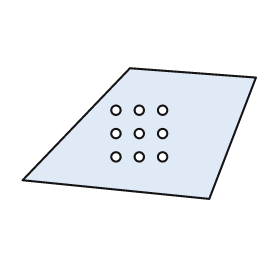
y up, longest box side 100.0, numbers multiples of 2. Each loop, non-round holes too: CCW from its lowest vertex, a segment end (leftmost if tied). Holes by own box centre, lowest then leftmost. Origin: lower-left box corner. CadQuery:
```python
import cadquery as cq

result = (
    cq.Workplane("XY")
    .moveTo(80.0, 0.0)
    .lineTo(100.0, 52.0)
    .lineTo(46.0, 56.0)
    .lineTo(0.0, 8.0)
    .close()
    .moveTo(40.0, 18.0)
    .circle(2.0)
    .moveTo(50.0, 18.0)
    .circle(2.0)
    .moveTo(60.0, 18.0)
    .circle(2.0)
    .moveTo(40.0, 28.0)
    .circle(2.0)
    .moveTo(50.0, 28.0)
    .circle(2.0)
    .moveTo(60.0, 28.0)
    .circle(2.0)
    .moveTo(40.0, 38.0)
    .circle(2.0)
    .moveTo(50.0, 38.0)
    .circle(2.0)
    .moveTo(60.0, 38.0)
    .circle(2.0)
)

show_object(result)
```